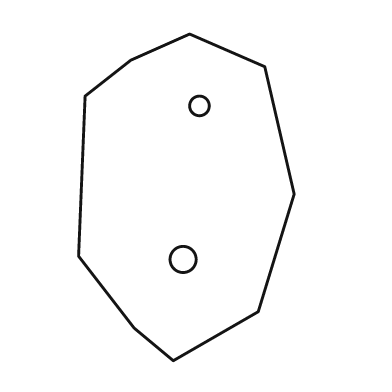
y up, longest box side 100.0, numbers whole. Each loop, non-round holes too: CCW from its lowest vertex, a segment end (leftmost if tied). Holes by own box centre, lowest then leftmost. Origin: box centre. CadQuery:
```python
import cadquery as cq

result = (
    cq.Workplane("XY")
    .moveTo(-4.0, -50.0)
    .lineTo(22.0, -35.0)
    .lineTo(33.0, 1.0)
    .lineTo(24.0, 40.0)
    .lineTo(1.0, 50.0)
    .lineTo(-17.0, 42.0)
    .lineTo(-31.0, 31.0)
    .lineTo(-33.0, -18.0)
    .lineTo(-16.0, -40.0)
    .close()
    .moveTo(-1.0, -19.0)
    .circle(4.0)
    .moveTo(4.0, 28.0)
    .circle(3.0)
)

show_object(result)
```